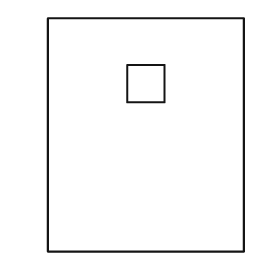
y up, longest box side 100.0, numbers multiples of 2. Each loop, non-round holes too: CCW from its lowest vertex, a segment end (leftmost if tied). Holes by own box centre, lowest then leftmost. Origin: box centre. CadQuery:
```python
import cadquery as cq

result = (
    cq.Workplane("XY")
    .moveTo(-42.0, -50.0)
    .lineTo(42.0, -50.0)
    .lineTo(42.0, 50.0)
    .lineTo(-42.0, 50.0)
    .close()
    .moveTo(-8.0, 14.0)
    .lineTo(8.0, 14.0)
    .lineTo(8.0, 30.0)
    .lineTo(-8.0, 30.0)
    .close()
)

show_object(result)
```